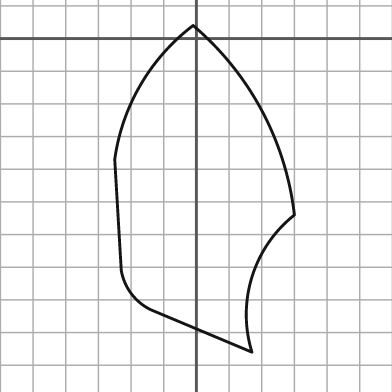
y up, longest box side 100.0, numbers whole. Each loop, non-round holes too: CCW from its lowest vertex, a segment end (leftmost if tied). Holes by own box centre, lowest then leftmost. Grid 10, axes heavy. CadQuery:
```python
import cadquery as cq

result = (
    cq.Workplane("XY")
    .moveTo(17.0, -96.0)
    .threePointArc((17.0, -73.0), (30.0, -54.0))
    .threePointArc((20.0, -22.0), (-1.0, 4.0))
    .threePointArc((-17.0, -14.0), (-25.0, -37.0))
    .lineTo(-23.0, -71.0)
    .threePointArc((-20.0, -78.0), (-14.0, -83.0))
    .close()
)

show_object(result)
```